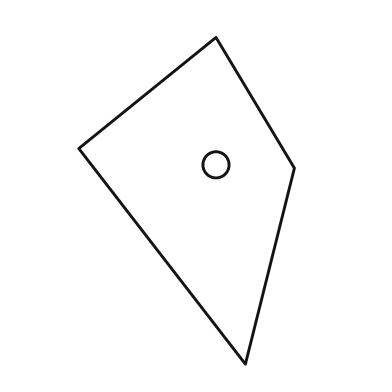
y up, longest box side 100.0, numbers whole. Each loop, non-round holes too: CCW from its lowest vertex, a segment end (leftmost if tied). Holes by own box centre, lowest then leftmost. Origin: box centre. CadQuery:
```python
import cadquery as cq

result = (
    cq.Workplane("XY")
    .moveTo(18.0, -50.0)
    .lineTo(33.0, 10.0)
    .lineTo(9.0, 50.0)
    .lineTo(-33.0, 16.0)
    .close()
    .moveTo(9.0, 11.0)
    .circle(4.0)
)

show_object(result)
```